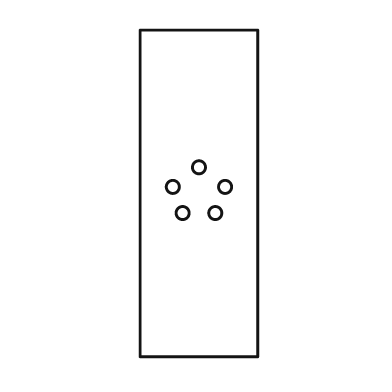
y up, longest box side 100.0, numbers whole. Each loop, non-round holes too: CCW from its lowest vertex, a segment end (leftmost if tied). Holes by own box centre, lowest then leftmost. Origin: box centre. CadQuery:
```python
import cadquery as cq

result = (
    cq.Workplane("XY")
    .moveTo(-18.0, -50.0)
    .lineTo(18.0, -50.0)
    .lineTo(18.0, 50.0)
    .lineTo(-18.0, 50.0)
    .close()
    .moveTo(-5.0, -6.0)
    .circle(2.0)
    .moveTo(5.0, -6.0)
    .circle(2.0)
    .moveTo(-8.0, 2.0)
    .circle(2.0)
    .moveTo(8.0, 2.0)
    .circle(2.0)
    .moveTo(0.0, 8.0)
    .circle(2.0)
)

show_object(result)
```